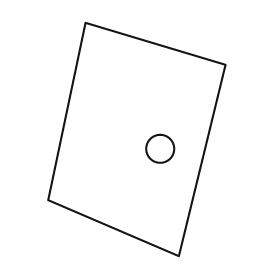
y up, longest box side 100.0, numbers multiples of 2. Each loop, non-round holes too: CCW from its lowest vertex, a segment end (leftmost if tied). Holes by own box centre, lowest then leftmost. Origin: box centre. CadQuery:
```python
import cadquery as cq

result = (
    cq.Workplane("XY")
    .moveTo(18.0, -50.0)
    .lineTo(38.0, 32.0)
    .lineTo(-22.0, 50.0)
    .lineTo(-38.0, -26.0)
    .close()
    .moveTo(10.0, -4.0)
    .circle(6.0)
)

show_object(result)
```